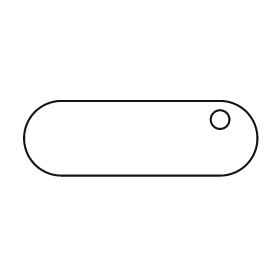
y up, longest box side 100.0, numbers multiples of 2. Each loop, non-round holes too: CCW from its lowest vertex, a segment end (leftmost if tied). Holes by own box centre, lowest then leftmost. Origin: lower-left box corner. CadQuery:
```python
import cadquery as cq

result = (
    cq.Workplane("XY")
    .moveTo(16.0, 0.0)
    .lineTo(84.0, 0.0)
    .threePointArc((100.0, 16.0), (84.0, 32.0))
    .lineTo(16.0, 32.0)
    .threePointArc((0.0, 16.0), (16.0, 0.0))
    .close()
    .moveTo(84.0, 24.0)
    .circle(4.0)
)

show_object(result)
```